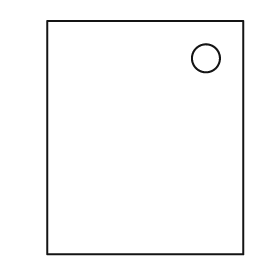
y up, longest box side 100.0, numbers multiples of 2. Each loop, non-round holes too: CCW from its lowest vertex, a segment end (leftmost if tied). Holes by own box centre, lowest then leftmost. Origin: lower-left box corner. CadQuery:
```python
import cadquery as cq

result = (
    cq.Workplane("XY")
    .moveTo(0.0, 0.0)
    .lineTo(84.0, 0.0)
    .lineTo(84.0, 100.0)
    .lineTo(0.0, 100.0)
    .close()
    .moveTo(68.0, 84.0)
    .circle(6.0)
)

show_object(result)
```